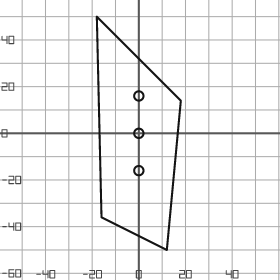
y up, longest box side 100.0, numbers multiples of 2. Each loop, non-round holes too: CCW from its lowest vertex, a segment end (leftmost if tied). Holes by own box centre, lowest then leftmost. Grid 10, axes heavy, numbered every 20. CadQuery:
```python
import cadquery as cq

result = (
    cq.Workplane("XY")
    .moveTo(12.0, -50.0)
    .lineTo(18.0, 14.0)
    .lineTo(-18.0, 50.0)
    .lineTo(-16.0, -36.0)
    .close()
    .moveTo(0.0, -16.0)
    .circle(2.0)
    .moveTo(0.0, 0.0)
    .circle(2.0)
    .moveTo(0.0, 16.0)
    .circle(2.0)
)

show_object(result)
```